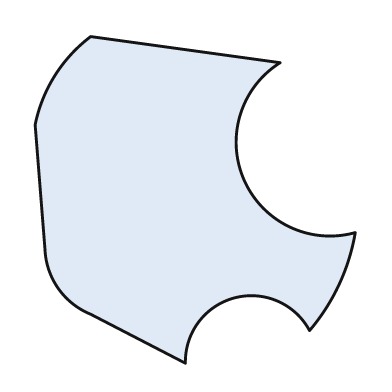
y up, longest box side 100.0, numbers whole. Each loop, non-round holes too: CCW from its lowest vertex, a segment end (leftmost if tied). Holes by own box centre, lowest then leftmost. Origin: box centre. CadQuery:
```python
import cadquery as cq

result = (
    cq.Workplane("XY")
    .moveTo(-3.0, -50.0)
    .threePointArc((12.0, -30.0), (35.0, -40.0))
    .threePointArc((44.0, -26.0), (49.0, -10.0))
    .threePointArc((15.0, 6.0), (26.0, 42.0))
    .lineTo(-32.0, 50.0)
    .threePointArc((-43.0, 38.0), (-49.0, 23.0))
    .lineTo(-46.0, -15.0)
    .threePointArc((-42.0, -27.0), (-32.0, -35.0))
    .close()
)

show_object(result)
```